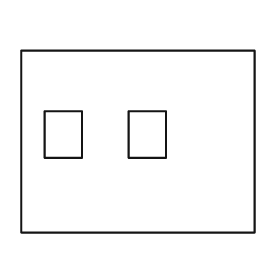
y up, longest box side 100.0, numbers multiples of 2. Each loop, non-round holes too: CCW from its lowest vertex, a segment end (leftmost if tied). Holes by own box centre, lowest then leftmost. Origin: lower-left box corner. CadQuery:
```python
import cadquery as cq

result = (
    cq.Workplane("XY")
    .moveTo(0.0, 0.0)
    .lineTo(100.0, 0.0)
    .lineTo(100.0, 78.0)
    .lineTo(0.0, 78.0)
    .close()
    .moveTo(10.0, 32.0)
    .lineTo(26.0, 32.0)
    .lineTo(26.0, 52.0)
    .lineTo(10.0, 52.0)
    .close()
    .moveTo(46.0, 32.0)
    .lineTo(62.0, 32.0)
    .lineTo(62.0, 52.0)
    .lineTo(46.0, 52.0)
    .close()
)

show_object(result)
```